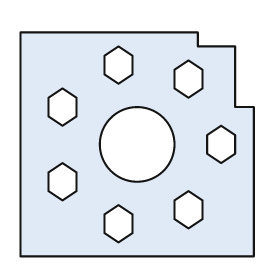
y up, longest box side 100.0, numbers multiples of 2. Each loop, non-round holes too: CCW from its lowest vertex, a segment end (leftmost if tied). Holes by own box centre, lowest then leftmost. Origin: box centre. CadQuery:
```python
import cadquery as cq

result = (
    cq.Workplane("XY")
    .moveTo(-50.0, -48.0)
    .lineTo(50.0, -48.0)
    .lineTo(50.0, 16.0)
    .lineTo(42.0, 16.0)
    .lineTo(42.0, 42.0)
    .lineTo(26.0, 42.0)
    .lineTo(26.0, 48.0)
    .lineTo(-50.0, 48.0)
    .close()
    .moveTo(-8.0, -42.0)
    .lineTo(-2.0, -38.0)
    .lineTo(-2.0, -30.0)
    .lineTo(-8.0, -26.0)
    .lineTo(-14.0, -30.0)
    .lineTo(-14.0, -38.0)
    .close()
    .moveTo(22.0, -36.0)
    .lineTo(28.0, -32.0)
    .lineTo(28.0, -24.0)
    .lineTo(22.0, -20.0)
    .lineTo(16.0, -24.0)
    .lineTo(16.0, -32.0)
    .close()
    .moveTo(-32.0, -24.0)
    .lineTo(-26.0, -20.0)
    .lineTo(-26.0, -12.0)
    .lineTo(-32.0, -8.0)
    .lineTo(-38.0, -12.0)
    .lineTo(-38.0, -20.0)
    .close()
    .moveTo(0.0, 0.0)
    .circle(16.0)
    .moveTo(36.0, -8.0)
    .lineTo(42.0, -4.0)
    .lineTo(42.0, 4.0)
    .lineTo(36.0, 8.0)
    .lineTo(30.0, 4.0)
    .lineTo(30.0, -4.0)
    .close()
    .moveTo(-32.0, 8.0)
    .lineTo(-26.0, 12.0)
    .lineTo(-26.0, 20.0)
    .lineTo(-32.0, 24.0)
    .lineTo(-38.0, 20.0)
    .lineTo(-38.0, 12.0)
    .close()
    .moveTo(22.0, 20.0)
    .lineTo(28.0, 24.0)
    .lineTo(28.0, 32.0)
    .lineTo(22.0, 36.0)
    .lineTo(16.0, 32.0)
    .lineTo(16.0, 24.0)
    .close()
    .moveTo(-8.0, 26.0)
    .lineTo(-2.0, 30.0)
    .lineTo(-2.0, 38.0)
    .lineTo(-8.0, 42.0)
    .lineTo(-14.0, 38.0)
    .lineTo(-14.0, 30.0)
    .close()
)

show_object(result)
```